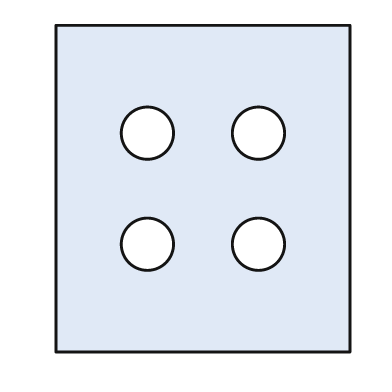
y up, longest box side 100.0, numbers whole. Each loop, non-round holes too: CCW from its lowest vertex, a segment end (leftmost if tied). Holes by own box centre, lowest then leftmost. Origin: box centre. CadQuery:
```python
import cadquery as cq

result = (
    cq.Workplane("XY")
    .moveTo(-45.0, -50.0)
    .lineTo(45.0, -50.0)
    .lineTo(45.0, 50.0)
    .lineTo(-45.0, 50.0)
    .close()
    .moveTo(-17.0, -17.0)
    .circle(8.0)
    .moveTo(17.0, -17.0)
    .circle(8.0)
    .moveTo(-17.0, 17.0)
    .circle(8.0)
    .moveTo(17.0, 17.0)
    .circle(8.0)
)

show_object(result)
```